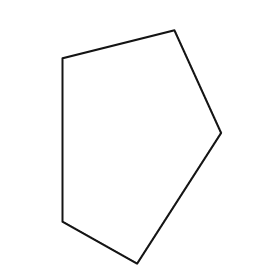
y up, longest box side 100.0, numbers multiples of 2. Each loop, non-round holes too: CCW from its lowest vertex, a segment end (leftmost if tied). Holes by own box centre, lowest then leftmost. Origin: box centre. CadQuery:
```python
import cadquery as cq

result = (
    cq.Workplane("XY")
    .moveTo(-2.0, -50.0)
    .lineTo(34.0, 6.0)
    .lineTo(14.0, 50.0)
    .lineTo(-34.0, 38.0)
    .lineTo(-34.0, -32.0)
    .close()
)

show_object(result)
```